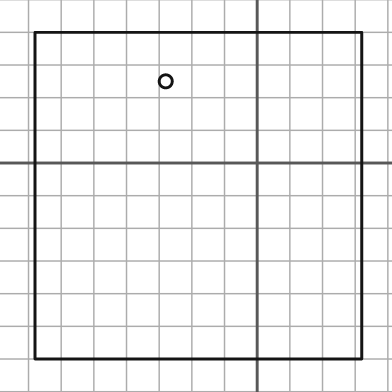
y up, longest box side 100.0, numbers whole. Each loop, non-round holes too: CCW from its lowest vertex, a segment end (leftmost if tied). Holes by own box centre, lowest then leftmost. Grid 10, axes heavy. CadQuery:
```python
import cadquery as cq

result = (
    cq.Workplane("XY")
    .moveTo(-68.0, -60.0)
    .lineTo(32.0, -60.0)
    .lineTo(32.0, 40.0)
    .lineTo(-68.0, 40.0)
    .close()
    .moveTo(-28.0, 25.0)
    .circle(2.0)
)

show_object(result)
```